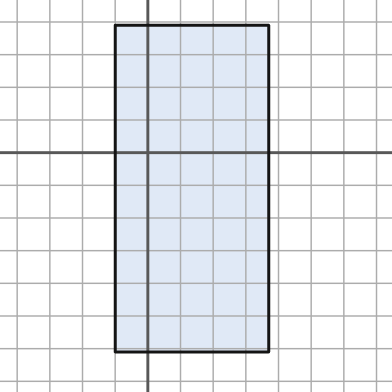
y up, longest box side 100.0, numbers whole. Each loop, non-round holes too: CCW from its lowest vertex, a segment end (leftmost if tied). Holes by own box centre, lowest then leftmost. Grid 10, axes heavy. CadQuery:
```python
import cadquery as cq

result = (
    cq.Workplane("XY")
    .moveTo(-10.0, -61.0)
    .lineTo(37.0, -61.0)
    .lineTo(37.0, 39.0)
    .lineTo(-10.0, 39.0)
    .close()
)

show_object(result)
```